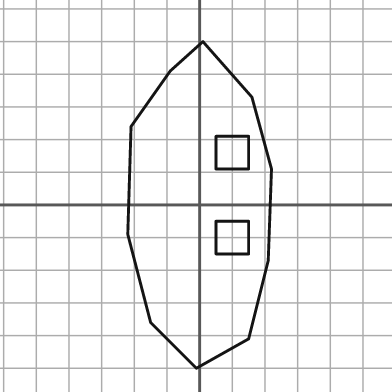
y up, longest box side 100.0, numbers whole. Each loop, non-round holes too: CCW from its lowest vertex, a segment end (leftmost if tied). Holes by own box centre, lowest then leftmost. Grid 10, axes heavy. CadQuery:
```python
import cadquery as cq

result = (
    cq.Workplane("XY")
    .moveTo(-1.0, -50.0)
    .lineTo(15.0, -41.0)
    .lineTo(21.0, -17.0)
    .lineTo(22.0, 11.0)
    .lineTo(16.0, 33.0)
    .lineTo(1.0, 50.0)
    .lineTo(-9.0, 41.0)
    .lineTo(-21.0, 24.0)
    .lineTo(-22.0, -9.0)
    .lineTo(-15.0, -36.0)
    .close()
    .moveTo(5.0, -15.0)
    .lineTo(15.0, -15.0)
    .lineTo(15.0, -5.0)
    .lineTo(5.0, -5.0)
    .close()
    .moveTo(5.0, 11.0)
    .lineTo(15.0, 11.0)
    .lineTo(15.0, 21.0)
    .lineTo(5.0, 21.0)
    .close()
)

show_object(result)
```